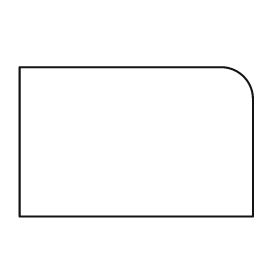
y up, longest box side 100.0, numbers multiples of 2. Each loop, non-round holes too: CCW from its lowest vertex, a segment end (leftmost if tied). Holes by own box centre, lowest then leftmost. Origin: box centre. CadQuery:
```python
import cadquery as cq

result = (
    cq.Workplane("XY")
    .moveTo(-50.0, -32.0)
    .lineTo(50.0, -32.0)
    .lineTo(50.0, 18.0)
    .threePointArc((46.0, 28.0), (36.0, 32.0))
    .lineTo(-50.0, 32.0)
    .close()
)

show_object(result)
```